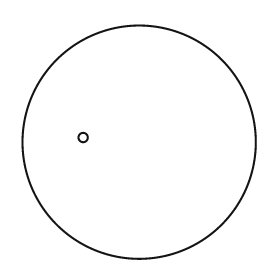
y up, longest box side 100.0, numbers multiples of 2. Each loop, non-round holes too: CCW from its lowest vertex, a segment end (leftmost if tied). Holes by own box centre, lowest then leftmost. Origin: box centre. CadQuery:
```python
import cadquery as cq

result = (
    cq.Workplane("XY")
    .moveTo(0.0, 0.0)
    .circle(50.0)
    .moveTo(-24.0, 2.0)
    .circle(2.0)
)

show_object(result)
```